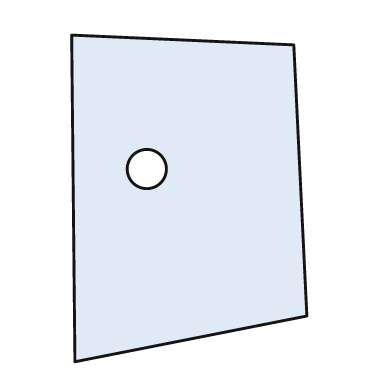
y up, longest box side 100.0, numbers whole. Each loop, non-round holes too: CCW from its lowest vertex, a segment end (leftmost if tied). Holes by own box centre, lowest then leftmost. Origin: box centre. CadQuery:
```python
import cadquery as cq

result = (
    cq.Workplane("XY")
    .moveTo(-35.0, -50.0)
    .lineTo(36.0, -36.0)
    .lineTo(32.0, 47.0)
    .lineTo(-36.0, 50.0)
    .close()
    .moveTo(-13.0, 9.0)
    .circle(6.0)
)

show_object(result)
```